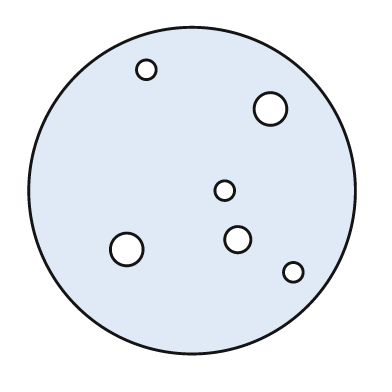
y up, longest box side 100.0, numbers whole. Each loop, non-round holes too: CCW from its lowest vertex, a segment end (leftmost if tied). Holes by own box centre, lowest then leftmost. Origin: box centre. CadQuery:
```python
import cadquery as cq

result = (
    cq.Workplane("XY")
    .moveTo(0.0, 0.0)
    .circle(50.0)
    .moveTo(31.0, -25.0)
    .circle(3.0)
    .moveTo(-20.0, -18.0)
    .circle(5.0)
    .moveTo(14.0, -15.0)
    .circle(4.0)
    .moveTo(10.0, 0.0)
    .circle(3.0)
    .moveTo(24.0, 25.0)
    .circle(5.0)
    .moveTo(-14.0, 37.0)
    .circle(3.0)
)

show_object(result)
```